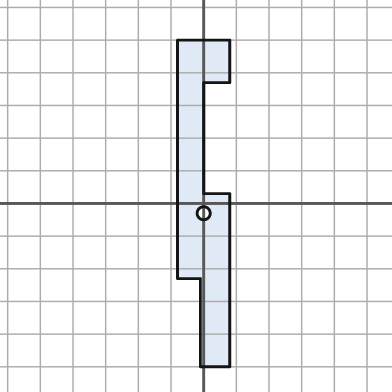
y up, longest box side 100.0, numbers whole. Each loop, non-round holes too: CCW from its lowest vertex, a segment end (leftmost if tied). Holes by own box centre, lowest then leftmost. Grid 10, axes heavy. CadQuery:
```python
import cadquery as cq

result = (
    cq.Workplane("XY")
    .moveTo(-1.0, -50.0)
    .lineTo(8.0, -50.0)
    .lineTo(8.0, 3.0)
    .lineTo(0.0, 3.0)
    .lineTo(0.0, 37.0)
    .lineTo(8.0, 37.0)
    .lineTo(8.0, 50.0)
    .lineTo(-8.0, 50.0)
    .lineTo(-8.0, -23.0)
    .lineTo(-1.0, -23.0)
    .close()
    .moveTo(0.0, -3.0)
    .circle(2.0)
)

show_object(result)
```